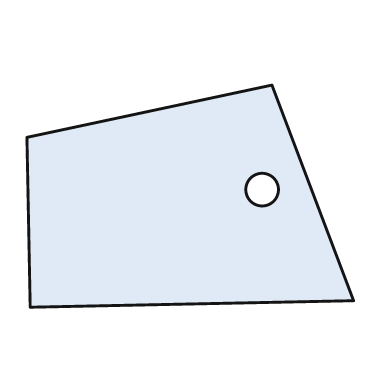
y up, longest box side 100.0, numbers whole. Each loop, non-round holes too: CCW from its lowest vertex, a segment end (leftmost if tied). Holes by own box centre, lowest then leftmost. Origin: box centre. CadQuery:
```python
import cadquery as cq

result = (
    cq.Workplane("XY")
    .moveTo(-49.0, -34.0)
    .lineTo(50.0, -32.0)
    .lineTo(25.0, 34.0)
    .lineTo(-50.0, 18.0)
    .close()
    .moveTo(22.0, 2.0)
    .circle(5.0)
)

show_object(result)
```